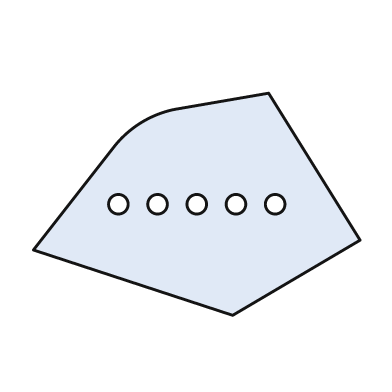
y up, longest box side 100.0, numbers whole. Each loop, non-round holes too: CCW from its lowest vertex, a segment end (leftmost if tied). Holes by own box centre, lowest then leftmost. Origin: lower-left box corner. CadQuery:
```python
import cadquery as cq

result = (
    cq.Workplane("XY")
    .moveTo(61.0, 0.0)
    .lineTo(100.0, 23.0)
    .lineTo(72.0, 68.0)
    .lineTo(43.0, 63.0)
    .threePointArc((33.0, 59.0), (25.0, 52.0))
    .lineTo(0.0, 20.0)
    .close()
    .moveTo(26.0, 34.0)
    .circle(3.0)
    .moveTo(38.0, 34.0)
    .circle(3.0)
    .moveTo(50.0, 34.0)
    .circle(3.0)
    .moveTo(62.0, 34.0)
    .circle(3.0)
    .moveTo(74.0, 34.0)
    .circle(3.0)
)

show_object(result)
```